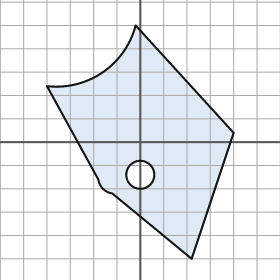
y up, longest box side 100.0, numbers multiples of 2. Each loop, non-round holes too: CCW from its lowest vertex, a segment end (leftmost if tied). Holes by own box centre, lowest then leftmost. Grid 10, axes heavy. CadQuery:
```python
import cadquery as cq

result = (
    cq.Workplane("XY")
    .moveTo(22.0, -50.0)
    .lineTo(40.0, 4.0)
    .lineTo(-2.0, 50.0)
    .threePointArc((-16.0, 30.0), (-40.0, 24.0))
    .lineTo(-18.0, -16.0)
    .threePointArc((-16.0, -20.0), (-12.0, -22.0))
    .close()
    .moveTo(0.0, -14.0)
    .circle(6.0)
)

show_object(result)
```